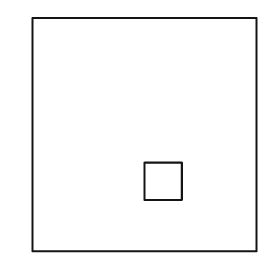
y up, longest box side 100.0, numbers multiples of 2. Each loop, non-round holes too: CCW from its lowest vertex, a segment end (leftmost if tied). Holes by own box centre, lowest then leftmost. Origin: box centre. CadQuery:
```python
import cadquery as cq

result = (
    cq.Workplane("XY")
    .moveTo(-48.0, -50.0)
    .lineTo(48.0, -50.0)
    .lineTo(48.0, 50.0)
    .lineTo(-48.0, 50.0)
    .close()
    .moveTo(0.0, -28.0)
    .lineTo(16.0, -28.0)
    .lineTo(16.0, -12.0)
    .lineTo(0.0, -12.0)
    .close()
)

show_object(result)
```